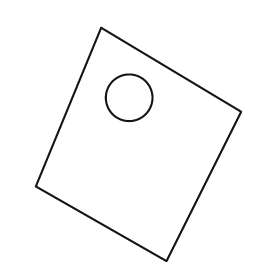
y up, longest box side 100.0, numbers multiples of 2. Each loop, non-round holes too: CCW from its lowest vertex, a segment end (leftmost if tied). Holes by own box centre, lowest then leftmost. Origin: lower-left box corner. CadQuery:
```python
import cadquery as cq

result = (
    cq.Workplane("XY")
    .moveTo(56.0, 0.0)
    .lineTo(88.0, 64.0)
    .lineTo(28.0, 100.0)
    .lineTo(0.0, 32.0)
    .close()
    .moveTo(40.0, 70.0)
    .circle(10.0)
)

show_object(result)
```